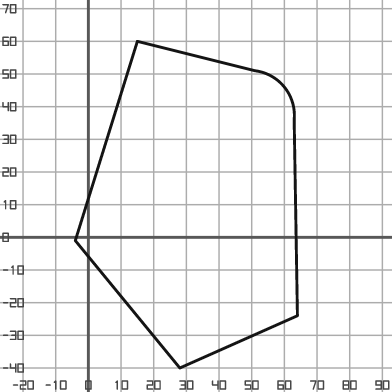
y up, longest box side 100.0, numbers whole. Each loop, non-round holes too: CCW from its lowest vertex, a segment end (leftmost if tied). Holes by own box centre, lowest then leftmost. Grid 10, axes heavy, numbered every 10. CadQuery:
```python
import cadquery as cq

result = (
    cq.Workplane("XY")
    .moveTo(28.0, -40.0)
    .lineTo(64.0, -24.0)
    .lineTo(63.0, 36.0)
    .threePointArc((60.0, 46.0), (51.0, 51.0))
    .lineTo(15.0, 60.0)
    .lineTo(-4.0, -1.0)
    .close()
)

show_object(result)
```